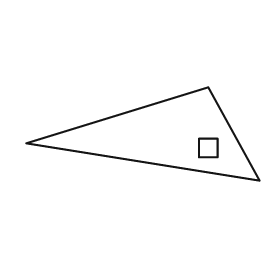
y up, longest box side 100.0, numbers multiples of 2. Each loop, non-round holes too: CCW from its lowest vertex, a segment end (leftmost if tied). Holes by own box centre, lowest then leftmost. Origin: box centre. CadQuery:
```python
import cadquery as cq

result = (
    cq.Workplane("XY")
    .moveTo(50.0, -20.0)
    .lineTo(28.0, 20.0)
    .lineTo(-50.0, -4.0)
    .close()
    .moveTo(24.0, -10.0)
    .lineTo(32.0, -10.0)
    .lineTo(32.0, -2.0)
    .lineTo(24.0, -2.0)
    .close()
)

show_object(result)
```